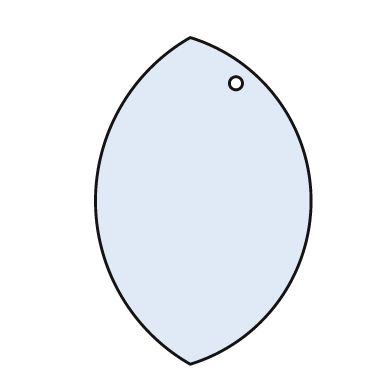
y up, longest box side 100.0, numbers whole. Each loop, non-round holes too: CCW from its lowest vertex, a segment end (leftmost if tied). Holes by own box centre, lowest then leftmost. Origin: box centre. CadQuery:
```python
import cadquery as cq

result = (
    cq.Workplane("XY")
    .moveTo(-4.0, -50.0)
    .threePointArc((33.0, 0.0), (-4.0, 50.0))
    .threePointArc((-33.0, 0.0), (-4.0, -50.0))
    .close()
    .moveTo(10.0, 36.0)
    .circle(2.0)
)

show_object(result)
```